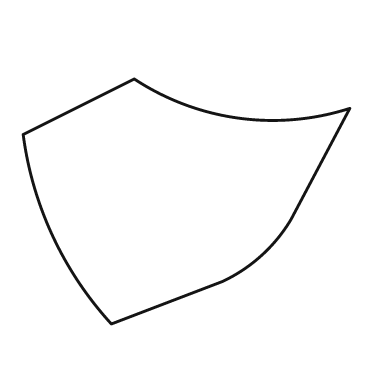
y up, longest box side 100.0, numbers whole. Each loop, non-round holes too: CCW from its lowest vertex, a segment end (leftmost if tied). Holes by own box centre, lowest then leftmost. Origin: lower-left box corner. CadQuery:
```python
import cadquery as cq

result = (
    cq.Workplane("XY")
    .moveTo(27.0, 0.0)
    .lineTo(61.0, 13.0)
    .threePointArc((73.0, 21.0), (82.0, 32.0))
    .lineTo(100.0, 66.0)
    .threePointArc((66.0, 63.0), (34.0, 75.0))
    .lineTo(0.0, 58.0)
    .threePointArc((9.0, 27.0), (27.0, 0.0))
    .close()
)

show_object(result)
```